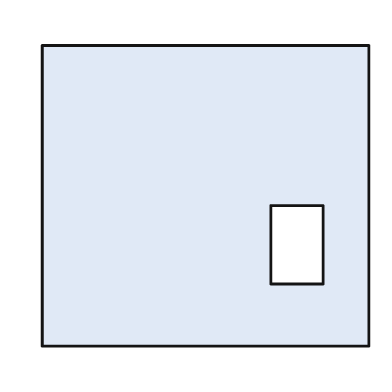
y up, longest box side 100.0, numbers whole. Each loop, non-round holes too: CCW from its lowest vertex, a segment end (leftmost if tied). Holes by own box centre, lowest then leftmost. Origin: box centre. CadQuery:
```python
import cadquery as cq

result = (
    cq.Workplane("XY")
    .moveTo(-50.0, -46.0)
    .lineTo(50.0, -46.0)
    .lineTo(50.0, 46.0)
    .lineTo(-50.0, 46.0)
    .close()
    .moveTo(20.0, -27.0)
    .lineTo(36.0, -27.0)
    .lineTo(36.0, -3.0)
    .lineTo(20.0, -3.0)
    .close()
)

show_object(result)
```